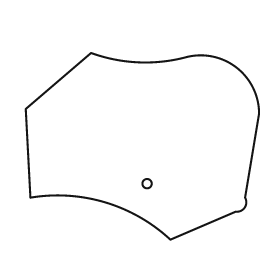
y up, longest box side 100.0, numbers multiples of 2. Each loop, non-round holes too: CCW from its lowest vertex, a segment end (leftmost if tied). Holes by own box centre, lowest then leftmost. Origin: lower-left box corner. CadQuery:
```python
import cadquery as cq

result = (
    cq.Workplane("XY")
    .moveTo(62.0, 0.0)
    .lineTo(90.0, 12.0)
    .threePointArc((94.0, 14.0), (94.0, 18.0))
    .lineTo(100.0, 54.0)
    .threePointArc((90.0, 74.0), (68.0, 78.0))
    .threePointArc((48.0, 76.0), (28.0, 80.0))
    .lineTo(0.0, 56.0)
    .lineTo(2.0, 18.0)
    .threePointArc((34.0, 16.0), (62.0, 0.0))
    .close()
    .moveTo(52.0, 24.0)
    .circle(2.0)
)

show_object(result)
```